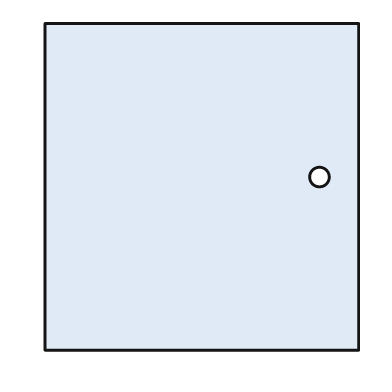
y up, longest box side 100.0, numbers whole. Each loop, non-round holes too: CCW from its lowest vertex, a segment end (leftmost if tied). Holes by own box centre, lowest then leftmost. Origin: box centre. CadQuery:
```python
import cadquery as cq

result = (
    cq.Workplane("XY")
    .moveTo(-48.0, -50.0)
    .lineTo(48.0, -50.0)
    .lineTo(48.0, 50.0)
    .lineTo(-48.0, 50.0)
    .close()
    .moveTo(36.0, 3.0)
    .circle(3.0)
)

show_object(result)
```